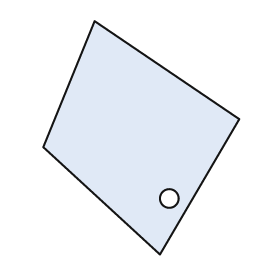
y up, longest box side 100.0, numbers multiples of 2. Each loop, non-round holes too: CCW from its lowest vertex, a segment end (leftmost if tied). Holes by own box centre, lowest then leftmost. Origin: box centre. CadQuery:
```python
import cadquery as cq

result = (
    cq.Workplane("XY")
    .moveTo(8.0, -50.0)
    .lineTo(42.0, 8.0)
    .lineTo(-20.0, 50.0)
    .lineTo(-42.0, -4.0)
    .close()
    .moveTo(12.0, -26.0)
    .circle(4.0)
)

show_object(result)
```